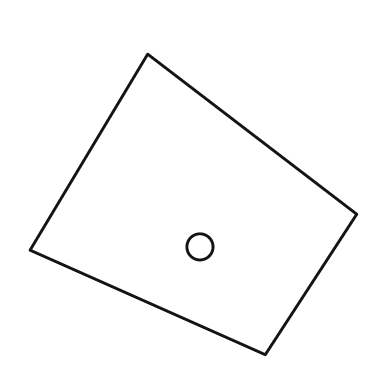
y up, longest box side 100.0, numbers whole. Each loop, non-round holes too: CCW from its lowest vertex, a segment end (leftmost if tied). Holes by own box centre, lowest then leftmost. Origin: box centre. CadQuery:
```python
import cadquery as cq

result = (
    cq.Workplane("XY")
    .moveTo(22.0, -46.0)
    .lineTo(50.0, -3.0)
    .lineTo(-14.0, 46.0)
    .lineTo(-50.0, -14.0)
    .close()
    .moveTo(2.0, -13.0)
    .circle(4.0)
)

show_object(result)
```